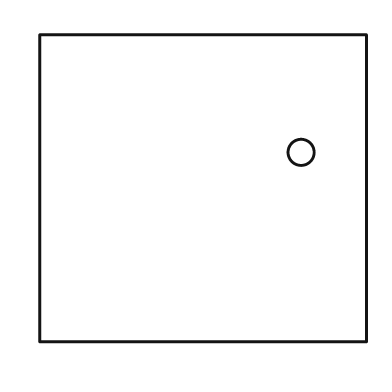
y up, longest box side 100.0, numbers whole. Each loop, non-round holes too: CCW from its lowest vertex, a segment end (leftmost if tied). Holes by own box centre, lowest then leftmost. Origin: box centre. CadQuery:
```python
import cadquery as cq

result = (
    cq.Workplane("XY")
    .moveTo(-50.0, -47.0)
    .lineTo(50.0, -47.0)
    .lineTo(50.0, 47.0)
    .lineTo(-50.0, 47.0)
    .close()
    .moveTo(30.0, 11.0)
    .circle(4.0)
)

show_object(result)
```